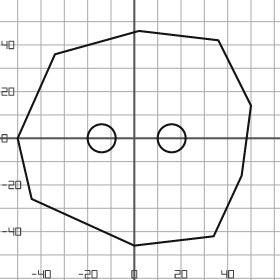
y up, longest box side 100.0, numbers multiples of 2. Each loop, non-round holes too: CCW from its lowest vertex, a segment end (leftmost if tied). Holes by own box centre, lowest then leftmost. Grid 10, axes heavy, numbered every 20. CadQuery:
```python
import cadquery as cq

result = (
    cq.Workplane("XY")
    .moveTo(0.0, -46.0)
    .lineTo(34.0, -42.0)
    .lineTo(46.0, -16.0)
    .lineTo(50.0, 14.0)
    .lineTo(36.0, 42.0)
    .lineTo(2.0, 46.0)
    .lineTo(-34.0, 36.0)
    .lineTo(-50.0, 0.0)
    .lineTo(-44.0, -26.0)
    .close()
    .moveTo(-14.0, 0.0)
    .circle(6.0)
    .moveTo(16.0, 0.0)
    .circle(6.0)
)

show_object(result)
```